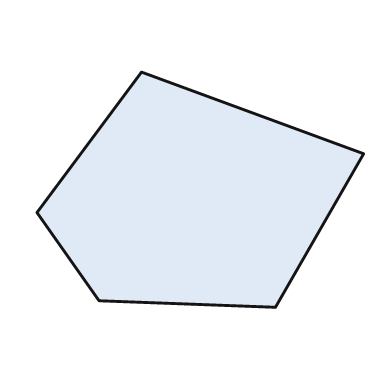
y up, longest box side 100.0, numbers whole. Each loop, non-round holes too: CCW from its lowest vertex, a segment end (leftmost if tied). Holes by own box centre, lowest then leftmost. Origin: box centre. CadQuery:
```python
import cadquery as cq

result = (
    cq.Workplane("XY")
    .moveTo(23.0, -36.0)
    .lineTo(50.0, 11.0)
    .lineTo(-18.0, 36.0)
    .lineTo(-50.0, -7.0)
    .lineTo(-31.0, -34.0)
    .close()
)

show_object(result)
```